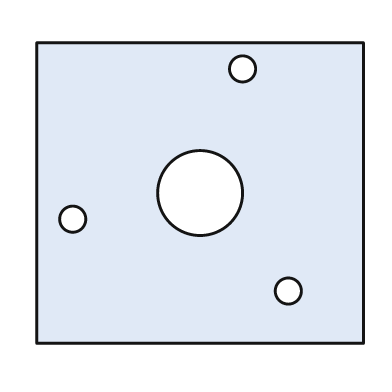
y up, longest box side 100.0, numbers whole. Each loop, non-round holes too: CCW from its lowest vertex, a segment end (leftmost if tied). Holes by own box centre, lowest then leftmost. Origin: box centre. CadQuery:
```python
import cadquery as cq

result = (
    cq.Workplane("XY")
    .moveTo(-50.0, -46.0)
    .lineTo(50.0, -46.0)
    .lineTo(50.0, 46.0)
    .lineTo(-50.0, 46.0)
    .close()
    .moveTo(27.0, -30.0)
    .circle(4.0)
    .moveTo(-39.0, -8.0)
    .circle(4.0)
    .moveTo(0.0, 0.0)
    .circle(13.0)
    .moveTo(13.0, 38.0)
    .circle(4.0)
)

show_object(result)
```